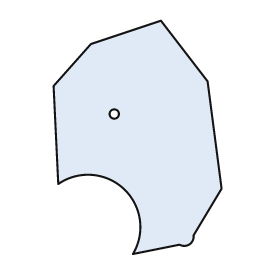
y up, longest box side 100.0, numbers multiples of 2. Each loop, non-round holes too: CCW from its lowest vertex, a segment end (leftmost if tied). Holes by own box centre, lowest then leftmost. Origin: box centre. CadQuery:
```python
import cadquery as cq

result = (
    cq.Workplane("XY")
    .moveTo(-2.0, -50.0)
    .lineTo(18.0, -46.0)
    .threePointArc((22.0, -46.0), (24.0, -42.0))
    .lineTo(36.0, -22.0)
    .lineTo(30.0, 24.0)
    .lineTo(10.0, 50.0)
    .lineTo(-20.0, 40.0)
    .lineTo(-36.0, 22.0)
    .lineTo(-34.0, -20.0)
    .threePointArc((-6.0, -22.0), (-2.0, -50.0))
    .close()
    .moveTo(-10.0, 10.0)
    .circle(2.0)
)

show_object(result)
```